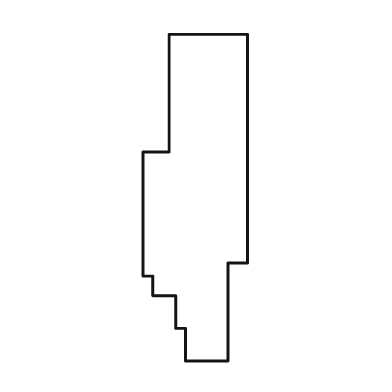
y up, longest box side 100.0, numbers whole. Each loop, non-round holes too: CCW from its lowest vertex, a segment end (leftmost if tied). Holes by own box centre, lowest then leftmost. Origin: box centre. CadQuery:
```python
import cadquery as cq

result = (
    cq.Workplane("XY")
    .moveTo(-3.0, -50.0)
    .lineTo(10.0, -50.0)
    .lineTo(10.0, -20.0)
    .lineTo(16.0, -20.0)
    .lineTo(16.0, 50.0)
    .lineTo(-8.0, 50.0)
    .lineTo(-8.0, 14.0)
    .lineTo(-16.0, 14.0)
    .lineTo(-16.0, -24.0)
    .lineTo(-13.0, -24.0)
    .lineTo(-13.0, -30.0)
    .lineTo(-6.0, -30.0)
    .lineTo(-6.0, -40.0)
    .lineTo(-3.0, -40.0)
    .close()
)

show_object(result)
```